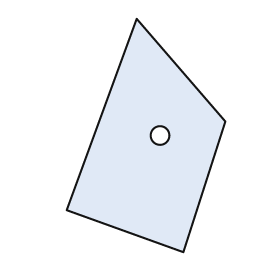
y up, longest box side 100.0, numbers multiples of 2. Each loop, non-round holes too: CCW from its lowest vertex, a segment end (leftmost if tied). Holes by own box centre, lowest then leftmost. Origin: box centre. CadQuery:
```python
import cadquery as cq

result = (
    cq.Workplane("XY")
    .moveTo(16.0, -50.0)
    .lineTo(34.0, 6.0)
    .lineTo(-4.0, 50.0)
    .lineTo(-34.0, -32.0)
    .close()
    .moveTo(6.0, 0.0)
    .circle(4.0)
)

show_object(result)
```